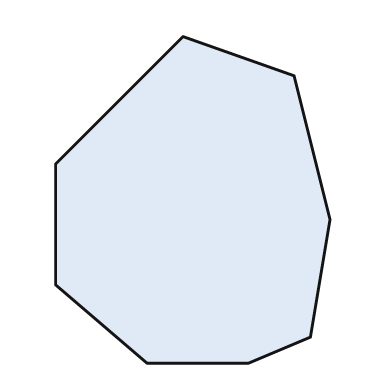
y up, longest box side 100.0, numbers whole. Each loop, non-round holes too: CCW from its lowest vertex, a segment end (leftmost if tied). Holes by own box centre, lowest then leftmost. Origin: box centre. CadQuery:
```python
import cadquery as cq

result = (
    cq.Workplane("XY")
    .moveTo(-14.0, -50.0)
    .lineTo(17.0, -50.0)
    .lineTo(36.0, -42.0)
    .lineTo(42.0, -6.0)
    .lineTo(31.0, 38.0)
    .lineTo(-3.0, 50.0)
    .lineTo(-42.0, 11.0)
    .lineTo(-42.0, -26.0)
    .close()
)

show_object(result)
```